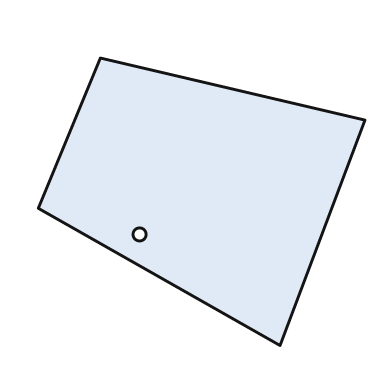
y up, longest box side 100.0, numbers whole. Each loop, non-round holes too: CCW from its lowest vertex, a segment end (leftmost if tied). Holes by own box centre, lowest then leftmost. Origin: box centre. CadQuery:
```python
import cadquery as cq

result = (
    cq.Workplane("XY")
    .moveTo(24.0, -44.0)
    .lineTo(50.0, 25.0)
    .lineTo(-31.0, 44.0)
    .lineTo(-50.0, -2.0)
    .close()
    .moveTo(-19.0, -10.0)
    .circle(2.0)
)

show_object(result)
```